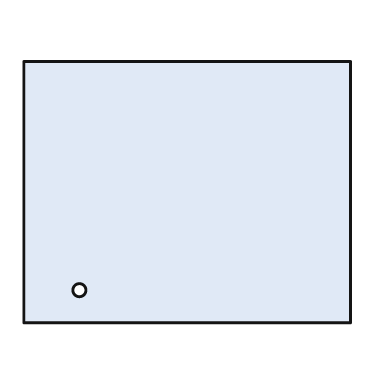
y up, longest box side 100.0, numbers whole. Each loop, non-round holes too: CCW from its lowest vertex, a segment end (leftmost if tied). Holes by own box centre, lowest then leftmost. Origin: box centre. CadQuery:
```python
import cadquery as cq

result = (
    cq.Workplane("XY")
    .moveTo(-50.0, -40.0)
    .lineTo(50.0, -40.0)
    .lineTo(50.0, 40.0)
    .lineTo(-50.0, 40.0)
    .close()
    .moveTo(-33.0, -30.0)
    .circle(2.0)
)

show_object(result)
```